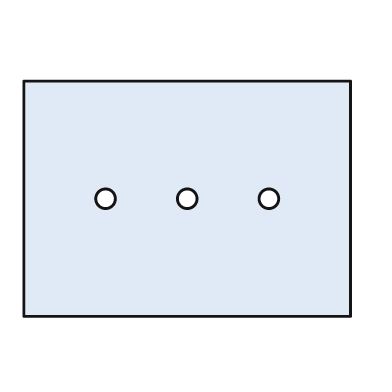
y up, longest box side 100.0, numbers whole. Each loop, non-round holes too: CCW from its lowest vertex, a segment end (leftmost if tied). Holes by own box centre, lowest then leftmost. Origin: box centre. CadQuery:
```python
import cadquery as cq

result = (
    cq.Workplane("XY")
    .moveTo(-50.0, -36.0)
    .lineTo(50.0, -36.0)
    .lineTo(50.0, 36.0)
    .lineTo(-50.0, 36.0)
    .close()
    .moveTo(-25.0, 0.0)
    .circle(3.0)
    .moveTo(0.0, 0.0)
    .circle(3.0)
    .moveTo(25.0, 0.0)
    .circle(3.0)
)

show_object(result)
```